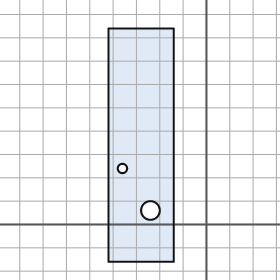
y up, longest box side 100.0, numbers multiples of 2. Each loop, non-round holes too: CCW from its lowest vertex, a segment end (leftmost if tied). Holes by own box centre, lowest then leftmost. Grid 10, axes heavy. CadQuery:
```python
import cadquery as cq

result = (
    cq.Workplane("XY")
    .moveTo(-42.0, -16.0)
    .lineTo(-14.0, -16.0)
    .lineTo(-14.0, 84.0)
    .lineTo(-42.0, 84.0)
    .close()
    .moveTo(-24.0, 6.0)
    .circle(4.0)
    .moveTo(-36.0, 24.0)
    .circle(2.0)
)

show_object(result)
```